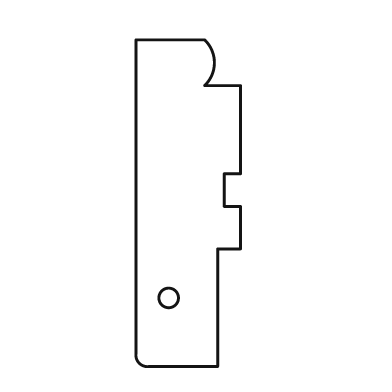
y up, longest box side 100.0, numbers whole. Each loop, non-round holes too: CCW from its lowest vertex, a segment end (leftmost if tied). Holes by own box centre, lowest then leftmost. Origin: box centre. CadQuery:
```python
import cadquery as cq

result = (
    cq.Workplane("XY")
    .moveTo(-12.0, -50.0)
    .lineTo(9.0, -50.0)
    .lineTo(9.0, -14.0)
    .lineTo(16.0, -14.0)
    .lineTo(16.0, -1.0)
    .lineTo(11.0, -1.0)
    .lineTo(11.0, 9.0)
    .lineTo(16.0, 9.0)
    .lineTo(16.0, 36.0)
    .lineTo(5.0, 36.0)
    .threePointArc((8.0, 43.0), (5.0, 50.0))
    .lineTo(-16.0, 50.0)
    .lineTo(-16.0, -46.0)
    .threePointArc((-15.0, -49.0), (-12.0, -50.0))
    .close()
    .moveTo(-6.0, -29.0)
    .circle(3.0)
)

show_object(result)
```